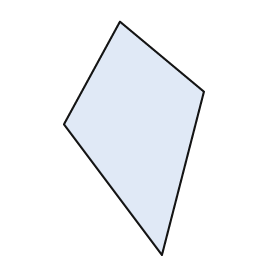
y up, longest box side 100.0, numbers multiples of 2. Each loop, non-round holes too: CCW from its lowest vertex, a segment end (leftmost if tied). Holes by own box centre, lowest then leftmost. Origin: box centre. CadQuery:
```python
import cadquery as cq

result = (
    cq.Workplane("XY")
    .moveTo(12.0, -50.0)
    .lineTo(30.0, 20.0)
    .lineTo(-6.0, 50.0)
    .lineTo(-30.0, 6.0)
    .close()
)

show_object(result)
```